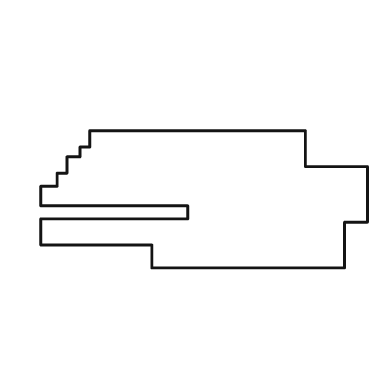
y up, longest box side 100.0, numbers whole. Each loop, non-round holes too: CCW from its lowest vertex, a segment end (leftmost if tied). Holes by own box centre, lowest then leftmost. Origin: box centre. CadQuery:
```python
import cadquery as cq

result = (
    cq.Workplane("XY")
    .moveTo(-16.0, -21.0)
    .lineTo(43.0, -21.0)
    .lineTo(43.0, -7.0)
    .lineTo(50.0, -7.0)
    .lineTo(50.0, 10.0)
    .lineTo(31.0, 10.0)
    .lineTo(31.0, 21.0)
    .lineTo(-35.0, 21.0)
    .lineTo(-35.0, 16.0)
    .lineTo(-38.0, 16.0)
    .lineTo(-38.0, 13.0)
    .lineTo(-42.0, 13.0)
    .lineTo(-42.0, 8.0)
    .lineTo(-45.0, 8.0)
    .lineTo(-45.0, 4.0)
    .lineTo(-50.0, 4.0)
    .lineTo(-50.0, -2.0)
    .lineTo(-5.0, -2.0)
    .lineTo(-5.0, -6.0)
    .lineTo(-50.0, -6.0)
    .lineTo(-50.0, -14.0)
    .lineTo(-16.0, -14.0)
    .close()
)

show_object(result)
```